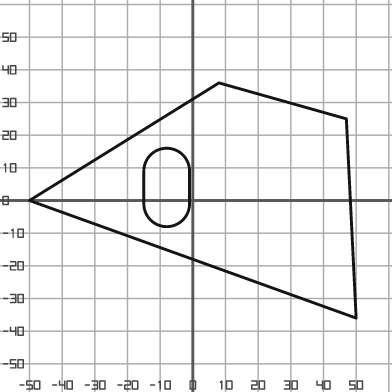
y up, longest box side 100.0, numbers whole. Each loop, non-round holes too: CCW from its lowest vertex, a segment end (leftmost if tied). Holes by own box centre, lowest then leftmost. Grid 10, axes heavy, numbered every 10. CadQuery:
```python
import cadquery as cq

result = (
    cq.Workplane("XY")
    .moveTo(50.0, -36.0)
    .lineTo(47.0, 25.0)
    .lineTo(8.0, 36.0)
    .lineTo(-50.0, 0.0)
    .close()
    .moveTo(-15.0, -1.0)
    .threePointArc((-8.0, -8.0), (-1.0, -1.0))
    .lineTo(-1.0, 9.0)
    .threePointArc((-8.0, 16.0), (-15.0, 9.0))
    .close()
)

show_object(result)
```